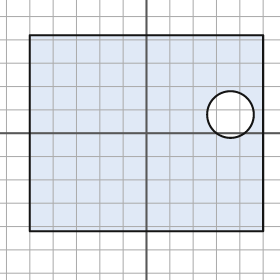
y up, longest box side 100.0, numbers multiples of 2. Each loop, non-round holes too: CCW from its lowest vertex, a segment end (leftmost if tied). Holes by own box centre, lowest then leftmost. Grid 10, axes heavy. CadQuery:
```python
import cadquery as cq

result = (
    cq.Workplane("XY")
    .moveTo(-50.0, -42.0)
    .lineTo(50.0, -42.0)
    .lineTo(50.0, 42.0)
    .lineTo(-50.0, 42.0)
    .close()
    .moveTo(36.0, 8.0)
    .circle(10.0)
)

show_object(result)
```